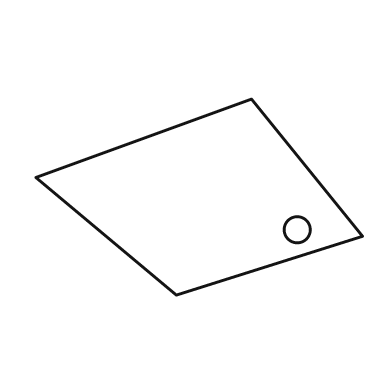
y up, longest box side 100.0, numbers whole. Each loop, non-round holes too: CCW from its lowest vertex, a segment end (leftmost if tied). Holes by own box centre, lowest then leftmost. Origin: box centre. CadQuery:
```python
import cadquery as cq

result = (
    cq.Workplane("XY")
    .moveTo(-7.0, -30.0)
    .lineTo(50.0, -12.0)
    .lineTo(16.0, 30.0)
    .lineTo(-50.0, 6.0)
    .close()
    .moveTo(30.0, -10.0)
    .circle(4.0)
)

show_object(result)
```